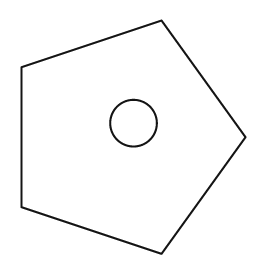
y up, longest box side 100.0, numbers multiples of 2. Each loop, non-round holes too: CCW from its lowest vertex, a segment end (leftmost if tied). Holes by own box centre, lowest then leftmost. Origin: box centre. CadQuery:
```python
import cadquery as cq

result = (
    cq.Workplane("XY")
    .moveTo(12.0, -50.0)
    .lineTo(48.0, 0.0)
    .lineTo(12.0, 50.0)
    .lineTo(-48.0, 30.0)
    .lineTo(-48.0, -30.0)
    .close()
    .moveTo(0.0, 6.0)
    .circle(10.0)
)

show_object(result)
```